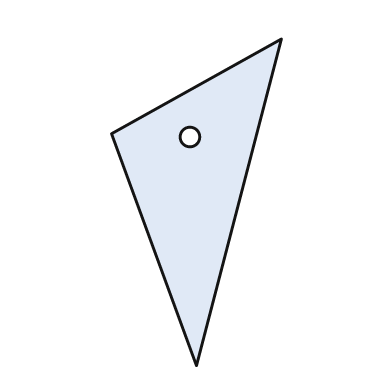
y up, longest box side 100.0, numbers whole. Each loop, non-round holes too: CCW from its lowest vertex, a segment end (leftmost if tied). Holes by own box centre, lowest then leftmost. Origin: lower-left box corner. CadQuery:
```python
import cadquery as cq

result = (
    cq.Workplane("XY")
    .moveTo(26.0, 0.0)
    .lineTo(52.0, 100.0)
    .lineTo(0.0, 71.0)
    .close()
    .moveTo(24.0, 70.0)
    .circle(3.0)
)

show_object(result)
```